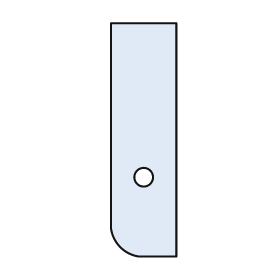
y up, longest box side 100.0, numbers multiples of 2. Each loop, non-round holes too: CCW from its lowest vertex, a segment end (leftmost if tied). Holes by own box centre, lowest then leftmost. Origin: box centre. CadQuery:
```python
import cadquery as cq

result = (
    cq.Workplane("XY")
    .moveTo(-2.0, -50.0)
    .lineTo(14.0, -50.0)
    .lineTo(14.0, 50.0)
    .lineTo(-14.0, 50.0)
    .lineTo(-14.0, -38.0)
    .threePointArc((-10.0, -46.0), (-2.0, -50.0))
    .close()
    .moveTo(0.0, -16.0)
    .circle(4.0)
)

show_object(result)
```